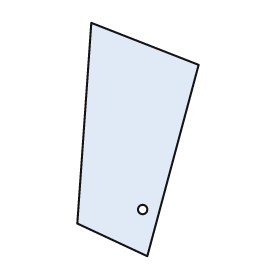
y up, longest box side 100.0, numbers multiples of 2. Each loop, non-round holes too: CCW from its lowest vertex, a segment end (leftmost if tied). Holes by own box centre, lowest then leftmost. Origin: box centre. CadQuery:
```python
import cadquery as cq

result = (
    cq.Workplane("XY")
    .moveTo(4.0, -50.0)
    .lineTo(26.0, 32.0)
    .lineTo(-20.0, 50.0)
    .lineTo(-26.0, -36.0)
    .close()
    .moveTo(2.0, -30.0)
    .circle(2.0)
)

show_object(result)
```